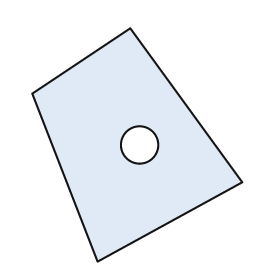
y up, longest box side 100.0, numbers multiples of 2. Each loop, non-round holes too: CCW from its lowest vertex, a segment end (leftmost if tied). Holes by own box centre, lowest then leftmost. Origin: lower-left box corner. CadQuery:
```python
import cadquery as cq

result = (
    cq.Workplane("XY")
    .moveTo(28.0, 0.0)
    .lineTo(90.0, 34.0)
    .lineTo(42.0, 100.0)
    .lineTo(0.0, 72.0)
    .close()
    .moveTo(46.0, 50.0)
    .circle(8.0)
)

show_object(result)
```